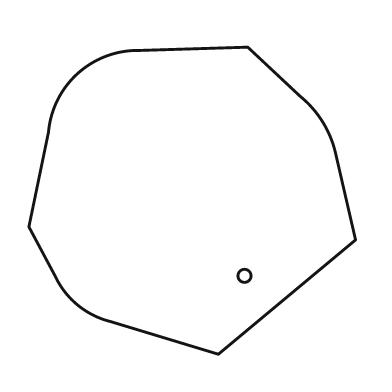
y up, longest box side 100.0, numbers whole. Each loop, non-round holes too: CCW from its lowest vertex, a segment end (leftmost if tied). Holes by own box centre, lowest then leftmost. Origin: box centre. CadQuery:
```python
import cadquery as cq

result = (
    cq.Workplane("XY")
    .moveTo(8.0, -47.0)
    .lineTo(50.0, -12.0)
    .lineTo(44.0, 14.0)
    .threePointArc((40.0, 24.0), (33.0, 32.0))
    .lineTo(17.0, 47.0)
    .lineTo(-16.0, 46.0)
    .threePointArc((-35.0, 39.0), (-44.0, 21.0))
    .lineTo(-50.0, -8.0)
    .lineTo(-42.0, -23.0)
    .threePointArc((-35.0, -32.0), (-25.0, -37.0))
    .close()
    .moveTo(16.0, -23.0)
    .circle(2.0)
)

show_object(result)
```